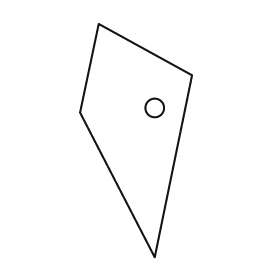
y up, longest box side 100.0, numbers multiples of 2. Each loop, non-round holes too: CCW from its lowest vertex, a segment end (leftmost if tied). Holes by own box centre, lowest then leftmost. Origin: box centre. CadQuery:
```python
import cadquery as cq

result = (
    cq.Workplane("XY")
    .moveTo(8.0, -50.0)
    .lineTo(24.0, 28.0)
    .lineTo(-16.0, 50.0)
    .lineTo(-24.0, 12.0)
    .close()
    .moveTo(8.0, 14.0)
    .circle(4.0)
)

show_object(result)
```